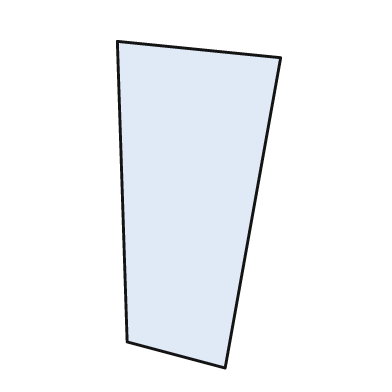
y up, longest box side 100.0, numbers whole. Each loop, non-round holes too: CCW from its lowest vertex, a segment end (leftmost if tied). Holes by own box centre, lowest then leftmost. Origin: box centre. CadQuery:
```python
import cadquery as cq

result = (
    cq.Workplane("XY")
    .moveTo(8.0, -50.0)
    .lineTo(25.0, 45.0)
    .lineTo(-25.0, 50.0)
    .lineTo(-22.0, -42.0)
    .close()
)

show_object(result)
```